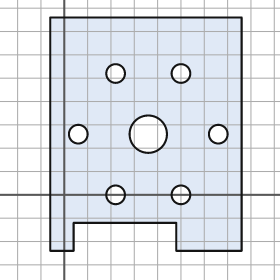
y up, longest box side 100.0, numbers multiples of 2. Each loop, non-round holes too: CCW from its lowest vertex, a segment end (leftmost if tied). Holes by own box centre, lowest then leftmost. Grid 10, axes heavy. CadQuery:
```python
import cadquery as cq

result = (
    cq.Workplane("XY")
    .moveTo(-6.0, -24.0)
    .lineTo(4.0, -24.0)
    .lineTo(4.0, -12.0)
    .lineTo(48.0, -12.0)
    .lineTo(48.0, -24.0)
    .lineTo(76.0, -24.0)
    .lineTo(76.0, 76.0)
    .lineTo(-6.0, 76.0)
    .close()
    .moveTo(22.0, 0.0)
    .circle(4.0)
    .moveTo(50.0, 0.0)
    .circle(4.0)
    .moveTo(6.0, 26.0)
    .circle(4.0)
    .moveTo(36.0, 26.0)
    .circle(8.0)
    .moveTo(66.0, 26.0)
    .circle(4.0)
    .moveTo(22.0, 52.0)
    .circle(4.0)
    .moveTo(50.0, 52.0)
    .circle(4.0)
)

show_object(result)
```